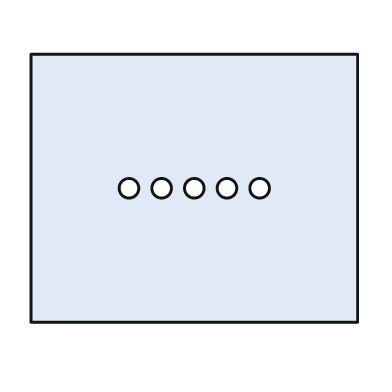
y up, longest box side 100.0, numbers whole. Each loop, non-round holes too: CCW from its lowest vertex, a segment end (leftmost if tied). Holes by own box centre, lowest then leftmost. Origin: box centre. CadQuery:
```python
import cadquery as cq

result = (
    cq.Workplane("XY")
    .moveTo(-50.0, -41.0)
    .lineTo(50.0, -41.0)
    .lineTo(50.0, 41.0)
    .lineTo(-50.0, 41.0)
    .close()
    .moveTo(-20.0, 0.0)
    .circle(3.0)
    .moveTo(-10.0, 0.0)
    .circle(3.0)
    .moveTo(0.0, 0.0)
    .circle(3.0)
    .moveTo(10.0, 0.0)
    .circle(3.0)
    .moveTo(20.0, 0.0)
    .circle(3.0)
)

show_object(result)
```